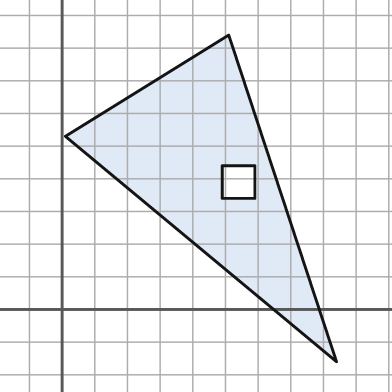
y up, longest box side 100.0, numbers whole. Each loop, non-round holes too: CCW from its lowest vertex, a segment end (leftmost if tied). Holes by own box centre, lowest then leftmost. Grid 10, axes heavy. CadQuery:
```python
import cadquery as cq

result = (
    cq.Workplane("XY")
    .moveTo(84.0, -16.0)
    .lineTo(51.0, 84.0)
    .lineTo(1.0, 53.0)
    .close()
    .moveTo(49.0, 34.0)
    .lineTo(59.0, 34.0)
    .lineTo(59.0, 44.0)
    .lineTo(49.0, 44.0)
    .close()
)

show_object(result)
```